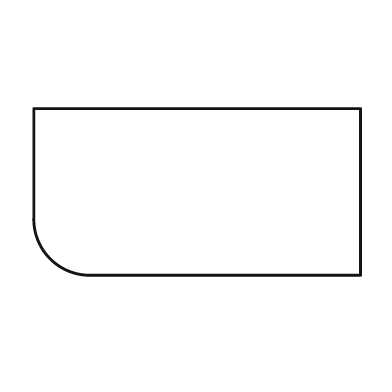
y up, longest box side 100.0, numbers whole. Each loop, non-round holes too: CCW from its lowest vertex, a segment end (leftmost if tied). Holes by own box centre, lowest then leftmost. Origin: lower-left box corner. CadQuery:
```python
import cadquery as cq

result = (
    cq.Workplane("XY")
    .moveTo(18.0, 0.0)
    .lineTo(100.0, 0.0)
    .lineTo(100.0, 51.0)
    .lineTo(0.0, 51.0)
    .lineTo(0.0, 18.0)
    .threePointArc((5.0, 5.0), (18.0, 0.0))
    .close()
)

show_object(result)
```